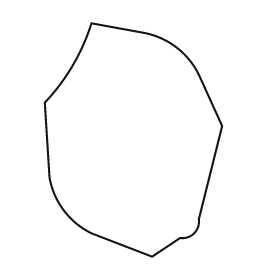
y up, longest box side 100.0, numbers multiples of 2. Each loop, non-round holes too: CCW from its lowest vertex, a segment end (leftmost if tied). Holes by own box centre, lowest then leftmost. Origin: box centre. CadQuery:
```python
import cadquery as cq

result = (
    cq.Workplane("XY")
    .moveTo(8.0, -50.0)
    .lineTo(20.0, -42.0)
    .threePointArc((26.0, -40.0), (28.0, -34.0))
    .lineTo(38.0, 6.0)
    .lineTo(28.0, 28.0)
    .threePointArc((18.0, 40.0), (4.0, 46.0))
    .lineTo(-18.0, 50.0)
    .threePointArc((-26.0, 32.0), (-38.0, 16.0))
    .lineTo(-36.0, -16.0)
    .threePointArc((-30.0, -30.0), (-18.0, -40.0))
    .close()
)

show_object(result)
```